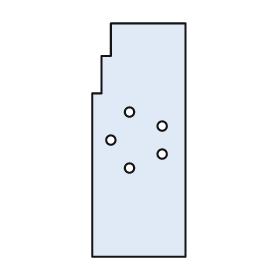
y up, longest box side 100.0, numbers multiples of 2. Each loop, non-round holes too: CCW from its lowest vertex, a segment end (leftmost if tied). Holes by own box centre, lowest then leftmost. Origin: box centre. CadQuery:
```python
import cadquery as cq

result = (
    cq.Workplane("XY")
    .moveTo(-20.0, -50.0)
    .lineTo(20.0, -50.0)
    .lineTo(20.0, 50.0)
    .lineTo(-12.0, 50.0)
    .lineTo(-12.0, 36.0)
    .lineTo(-16.0, 36.0)
    .lineTo(-16.0, 20.0)
    .lineTo(-20.0, 20.0)
    .close()
    .moveTo(-4.0, -12.0)
    .circle(2.0)
    .moveTo(10.0, -6.0)
    .circle(2.0)
    .moveTo(-12.0, 0.0)
    .circle(2.0)
    .moveTo(10.0, 6.0)
    .circle(2.0)
    .moveTo(-4.0, 12.0)
    .circle(2.0)
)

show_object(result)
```